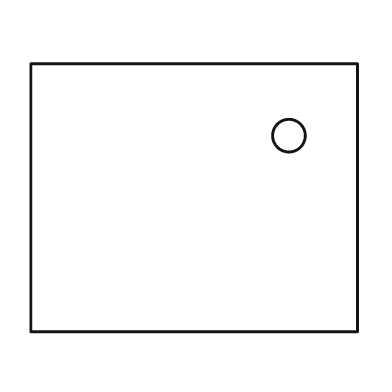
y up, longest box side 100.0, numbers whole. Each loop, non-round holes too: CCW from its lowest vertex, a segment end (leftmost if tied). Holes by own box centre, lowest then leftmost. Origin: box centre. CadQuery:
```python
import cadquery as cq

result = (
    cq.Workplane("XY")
    .moveTo(-50.0, -41.0)
    .lineTo(50.0, -41.0)
    .lineTo(50.0, 41.0)
    .lineTo(-50.0, 41.0)
    .close()
    .moveTo(29.0, 19.0)
    .circle(5.0)
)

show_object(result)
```